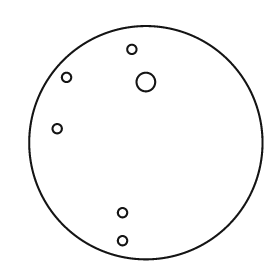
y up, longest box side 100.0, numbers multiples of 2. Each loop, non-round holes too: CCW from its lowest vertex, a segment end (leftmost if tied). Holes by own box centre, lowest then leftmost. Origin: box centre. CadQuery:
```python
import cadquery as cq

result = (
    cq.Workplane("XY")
    .moveTo(0.0, 0.0)
    .circle(50.0)
    .moveTo(-10.0, -42.0)
    .circle(2.0)
    .moveTo(-10.0, -30.0)
    .circle(2.0)
    .moveTo(-38.0, 6.0)
    .circle(2.0)
    .moveTo(0.0, 26.0)
    .circle(4.0)
    .moveTo(-34.0, 28.0)
    .circle(2.0)
    .moveTo(-6.0, 40.0)
    .circle(2.0)
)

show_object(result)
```